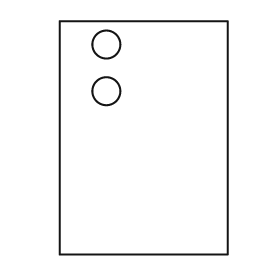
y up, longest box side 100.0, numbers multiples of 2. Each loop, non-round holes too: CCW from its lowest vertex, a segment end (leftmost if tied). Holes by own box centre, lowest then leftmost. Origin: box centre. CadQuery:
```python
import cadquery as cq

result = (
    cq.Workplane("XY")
    .moveTo(-36.0, -50.0)
    .lineTo(36.0, -50.0)
    .lineTo(36.0, 50.0)
    .lineTo(-36.0, 50.0)
    .close()
    .moveTo(-16.0, 20.0)
    .circle(6.0)
    .moveTo(-16.0, 40.0)
    .circle(6.0)
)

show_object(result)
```